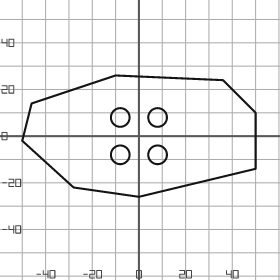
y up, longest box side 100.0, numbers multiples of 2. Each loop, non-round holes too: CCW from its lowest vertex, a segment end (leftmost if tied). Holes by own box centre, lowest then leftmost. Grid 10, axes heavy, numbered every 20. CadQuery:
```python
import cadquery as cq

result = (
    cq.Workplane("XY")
    .moveTo(0.0, -26.0)
    .lineTo(50.0, -14.0)
    .lineTo(50.0, 10.0)
    .lineTo(36.0, 24.0)
    .lineTo(-10.0, 26.0)
    .lineTo(-46.0, 14.0)
    .lineTo(-50.0, -2.0)
    .lineTo(-28.0, -22.0)
    .close()
    .moveTo(-8.0, -8.0)
    .circle(4.0)
    .moveTo(8.0, -8.0)
    .circle(4.0)
    .moveTo(-8.0, 8.0)
    .circle(4.0)
    .moveTo(8.0, 8.0)
    .circle(4.0)
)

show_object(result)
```